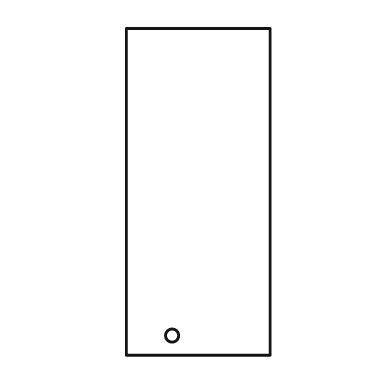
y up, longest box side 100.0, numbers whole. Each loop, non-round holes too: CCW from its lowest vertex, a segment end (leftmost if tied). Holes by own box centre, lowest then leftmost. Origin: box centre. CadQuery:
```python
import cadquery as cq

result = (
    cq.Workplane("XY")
    .moveTo(-22.0, -50.0)
    .lineTo(22.0, -50.0)
    .lineTo(22.0, 50.0)
    .lineTo(-22.0, 50.0)
    .close()
    .moveTo(-8.0, -44.0)
    .circle(2.0)
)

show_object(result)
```